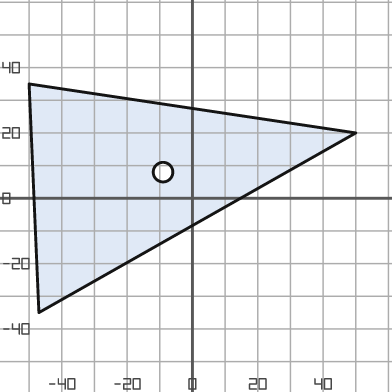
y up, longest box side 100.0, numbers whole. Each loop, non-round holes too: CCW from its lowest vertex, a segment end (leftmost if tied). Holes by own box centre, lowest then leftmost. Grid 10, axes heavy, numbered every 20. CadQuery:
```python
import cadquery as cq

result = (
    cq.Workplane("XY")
    .moveTo(-47.0, -35.0)
    .lineTo(50.0, 20.0)
    .lineTo(-50.0, 35.0)
    .close()
    .moveTo(-9.0, 8.0)
    .circle(3.0)
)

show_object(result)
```